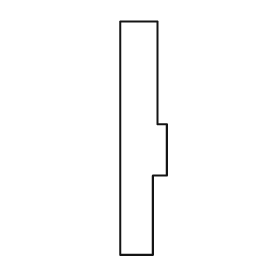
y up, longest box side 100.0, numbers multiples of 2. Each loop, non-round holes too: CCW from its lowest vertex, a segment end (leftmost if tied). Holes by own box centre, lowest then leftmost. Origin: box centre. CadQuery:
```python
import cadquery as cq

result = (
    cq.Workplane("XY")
    .moveTo(-10.0, -50.0)
    .lineTo(4.0, -50.0)
    .lineTo(4.0, -16.0)
    .lineTo(10.0, -16.0)
    .lineTo(10.0, 6.0)
    .lineTo(6.0, 6.0)
    .lineTo(6.0, 50.0)
    .lineTo(-10.0, 50.0)
    .close()
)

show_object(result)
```